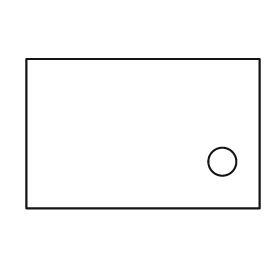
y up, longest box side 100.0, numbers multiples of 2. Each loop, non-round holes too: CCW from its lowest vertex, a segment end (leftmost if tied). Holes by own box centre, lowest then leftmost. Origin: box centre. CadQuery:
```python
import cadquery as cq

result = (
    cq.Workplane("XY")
    .moveTo(-50.0, -32.0)
    .lineTo(50.0, -32.0)
    .lineTo(50.0, 32.0)
    .lineTo(-50.0, 32.0)
    .close()
    .moveTo(34.0, -12.0)
    .circle(6.0)
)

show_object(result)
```